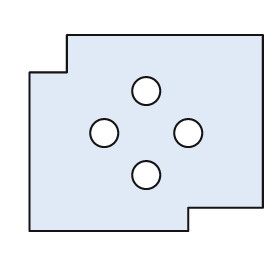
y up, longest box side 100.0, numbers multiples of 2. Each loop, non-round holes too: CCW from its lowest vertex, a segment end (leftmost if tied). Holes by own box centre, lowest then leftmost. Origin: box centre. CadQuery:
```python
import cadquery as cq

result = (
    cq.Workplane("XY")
    .moveTo(-50.0, -42.0)
    .lineTo(18.0, -42.0)
    .lineTo(18.0, -32.0)
    .lineTo(50.0, -32.0)
    .lineTo(50.0, 42.0)
    .lineTo(-34.0, 42.0)
    .lineTo(-34.0, 26.0)
    .lineTo(-50.0, 26.0)
    .close()
    .moveTo(0.0, -18.0)
    .circle(6.0)
    .moveTo(-18.0, 0.0)
    .circle(6.0)
    .moveTo(18.0, 0.0)
    .circle(6.0)
    .moveTo(0.0, 18.0)
    .circle(6.0)
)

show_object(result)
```